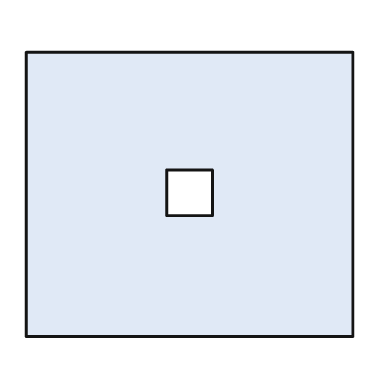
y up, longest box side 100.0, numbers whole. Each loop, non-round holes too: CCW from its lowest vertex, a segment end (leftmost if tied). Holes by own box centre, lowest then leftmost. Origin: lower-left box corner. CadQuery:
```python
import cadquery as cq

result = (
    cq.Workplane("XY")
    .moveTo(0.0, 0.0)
    .lineTo(100.0, 0.0)
    .lineTo(100.0, 87.0)
    .lineTo(0.0, 87.0)
    .close()
    .moveTo(43.0, 37.0)
    .lineTo(57.0, 37.0)
    .lineTo(57.0, 51.0)
    .lineTo(43.0, 51.0)
    .close()
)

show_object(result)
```